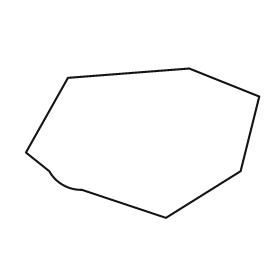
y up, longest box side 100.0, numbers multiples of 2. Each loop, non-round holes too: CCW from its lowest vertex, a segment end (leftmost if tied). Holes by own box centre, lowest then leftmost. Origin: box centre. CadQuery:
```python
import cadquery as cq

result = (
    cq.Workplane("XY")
    .moveTo(10.0, -32.0)
    .lineTo(42.0, -12.0)
    .lineTo(50.0, 20.0)
    .lineTo(20.0, 32.0)
    .lineTo(-32.0, 28.0)
    .lineTo(-50.0, -4.0)
    .lineTo(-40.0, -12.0)
    .threePointArc((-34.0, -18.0), (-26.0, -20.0))
    .close()
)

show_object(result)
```